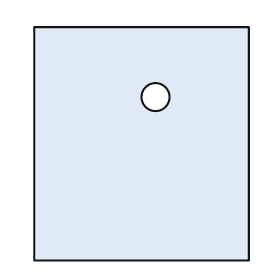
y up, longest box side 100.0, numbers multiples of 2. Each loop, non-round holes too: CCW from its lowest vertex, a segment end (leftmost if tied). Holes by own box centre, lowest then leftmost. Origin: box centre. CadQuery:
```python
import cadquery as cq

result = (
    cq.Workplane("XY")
    .moveTo(-46.0, -50.0)
    .lineTo(46.0, -50.0)
    .lineTo(46.0, 50.0)
    .lineTo(-46.0, 50.0)
    .close()
    .moveTo(6.0, 20.0)
    .circle(6.0)
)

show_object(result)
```